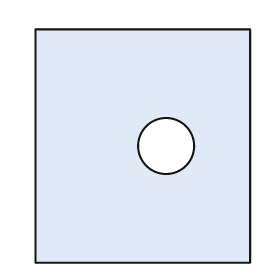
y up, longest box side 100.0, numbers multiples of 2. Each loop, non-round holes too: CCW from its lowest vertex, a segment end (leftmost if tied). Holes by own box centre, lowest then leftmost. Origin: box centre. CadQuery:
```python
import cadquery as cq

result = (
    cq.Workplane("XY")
    .moveTo(-46.0, -50.0)
    .lineTo(46.0, -50.0)
    .lineTo(46.0, 50.0)
    .lineTo(-46.0, 50.0)
    .close()
    .moveTo(10.0, 0.0)
    .circle(12.0)
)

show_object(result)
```